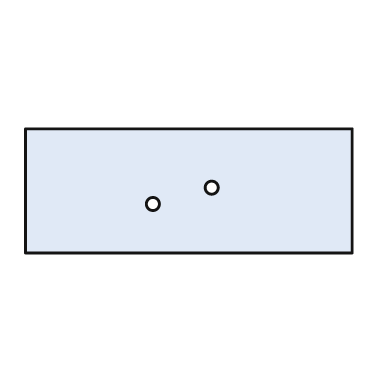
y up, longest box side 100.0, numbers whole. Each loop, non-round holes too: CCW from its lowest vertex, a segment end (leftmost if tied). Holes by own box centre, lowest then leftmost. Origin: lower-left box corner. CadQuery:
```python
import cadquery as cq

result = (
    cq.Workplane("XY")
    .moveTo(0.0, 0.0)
    .lineTo(100.0, 0.0)
    .lineTo(100.0, 38.0)
    .lineTo(0.0, 38.0)
    .close()
    .moveTo(39.0, 15.0)
    .circle(2.0)
    .moveTo(57.0, 20.0)
    .circle(2.0)
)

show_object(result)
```